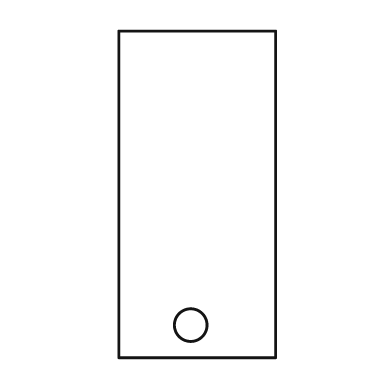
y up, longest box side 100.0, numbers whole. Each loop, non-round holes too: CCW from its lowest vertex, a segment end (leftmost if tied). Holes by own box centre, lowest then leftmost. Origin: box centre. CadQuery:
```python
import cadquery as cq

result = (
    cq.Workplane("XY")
    .moveTo(-24.0, -50.0)
    .lineTo(24.0, -50.0)
    .lineTo(24.0, 50.0)
    .lineTo(-24.0, 50.0)
    .close()
    .moveTo(-2.0, -40.0)
    .circle(5.0)
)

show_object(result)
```